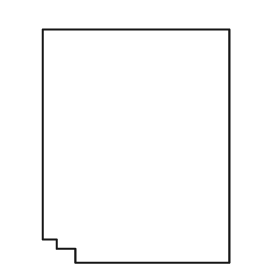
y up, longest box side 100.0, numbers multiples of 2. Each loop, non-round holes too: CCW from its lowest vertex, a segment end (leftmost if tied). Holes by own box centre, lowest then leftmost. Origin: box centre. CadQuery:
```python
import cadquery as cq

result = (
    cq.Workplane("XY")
    .moveTo(-26.0, -50.0)
    .lineTo(40.0, -50.0)
    .lineTo(40.0, 50.0)
    .lineTo(-40.0, 50.0)
    .lineTo(-40.0, -40.0)
    .lineTo(-34.0, -40.0)
    .lineTo(-34.0, -44.0)
    .lineTo(-26.0, -44.0)
    .close()
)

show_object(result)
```